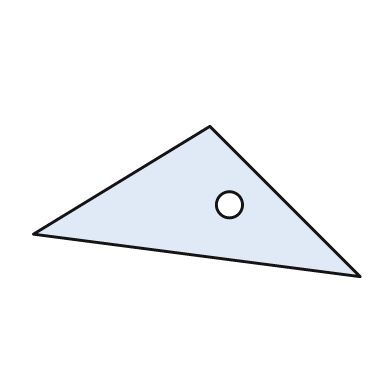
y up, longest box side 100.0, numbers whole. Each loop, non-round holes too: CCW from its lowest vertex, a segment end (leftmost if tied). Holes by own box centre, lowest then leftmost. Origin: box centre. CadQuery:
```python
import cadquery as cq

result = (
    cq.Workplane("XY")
    .moveTo(50.0, -23.0)
    .lineTo(4.0, 23.0)
    .lineTo(-50.0, -10.0)
    .close()
    .moveTo(10.0, -1.0)
    .circle(4.0)
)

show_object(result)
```